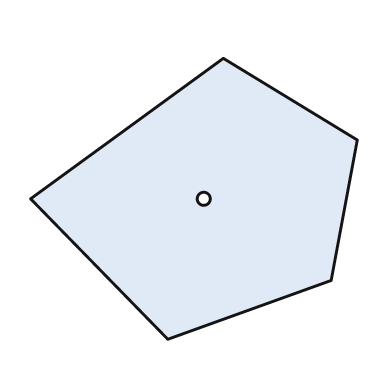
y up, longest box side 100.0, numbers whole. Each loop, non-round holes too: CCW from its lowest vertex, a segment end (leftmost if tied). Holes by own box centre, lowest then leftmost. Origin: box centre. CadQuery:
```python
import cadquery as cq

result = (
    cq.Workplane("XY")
    .moveTo(-8.0, -43.0)
    .lineTo(42.0, -25.0)
    .lineTo(50.0, 18.0)
    .lineTo(9.0, 43.0)
    .lineTo(-50.0, 0.0)
    .close()
    .moveTo(3.0, 0.0)
    .circle(2.0)
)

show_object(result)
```